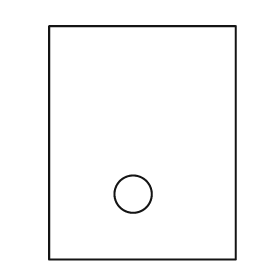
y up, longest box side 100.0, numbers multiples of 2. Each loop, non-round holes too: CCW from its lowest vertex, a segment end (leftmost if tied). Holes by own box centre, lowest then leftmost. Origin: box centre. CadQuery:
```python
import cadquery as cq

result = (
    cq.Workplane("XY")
    .moveTo(-40.0, -50.0)
    .lineTo(40.0, -50.0)
    .lineTo(40.0, 50.0)
    .lineTo(-40.0, 50.0)
    .close()
    .moveTo(-4.0, -22.0)
    .circle(8.0)
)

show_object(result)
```